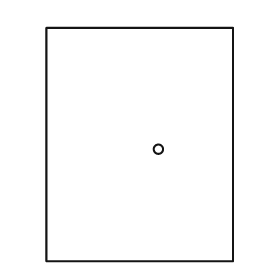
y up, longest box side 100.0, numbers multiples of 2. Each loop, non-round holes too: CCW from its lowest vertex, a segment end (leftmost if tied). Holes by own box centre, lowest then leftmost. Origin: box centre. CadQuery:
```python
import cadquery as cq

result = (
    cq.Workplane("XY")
    .moveTo(-40.0, -50.0)
    .lineTo(40.0, -50.0)
    .lineTo(40.0, 50.0)
    .lineTo(-40.0, 50.0)
    .close()
    .moveTo(8.0, -2.0)
    .circle(2.0)
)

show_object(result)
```